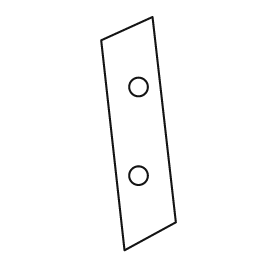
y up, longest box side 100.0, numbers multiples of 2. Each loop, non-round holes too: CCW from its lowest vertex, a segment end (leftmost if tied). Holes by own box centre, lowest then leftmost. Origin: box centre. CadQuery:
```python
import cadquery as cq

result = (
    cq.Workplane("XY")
    .moveTo(-6.0, -50.0)
    .lineTo(16.0, -38.0)
    .lineTo(6.0, 50.0)
    .lineTo(-16.0, 40.0)
    .close()
    .moveTo(0.0, -18.0)
    .circle(4.0)
    .moveTo(0.0, 20.0)
    .circle(4.0)
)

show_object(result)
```